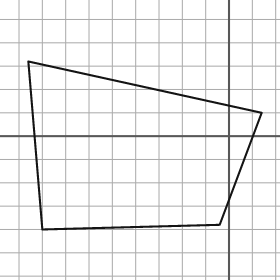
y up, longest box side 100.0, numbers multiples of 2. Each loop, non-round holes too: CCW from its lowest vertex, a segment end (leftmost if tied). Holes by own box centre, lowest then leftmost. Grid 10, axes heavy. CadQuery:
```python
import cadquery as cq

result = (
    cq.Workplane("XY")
    .moveTo(-80.0, -40.0)
    .lineTo(-4.0, -38.0)
    .lineTo(14.0, 10.0)
    .lineTo(-86.0, 32.0)
    .close()
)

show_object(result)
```